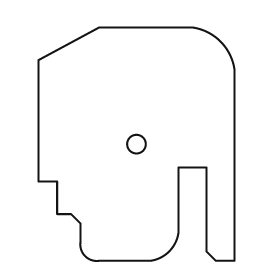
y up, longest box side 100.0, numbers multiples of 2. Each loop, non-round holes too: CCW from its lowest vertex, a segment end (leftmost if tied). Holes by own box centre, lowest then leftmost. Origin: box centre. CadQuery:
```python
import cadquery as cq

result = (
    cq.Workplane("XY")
    .moveTo(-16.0, -50.0)
    .lineTo(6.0, -50.0)
    .threePointArc((14.0, -46.0), (18.0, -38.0))
    .lineTo(18.0, -10.0)
    .lineTo(30.0, -10.0)
    .lineTo(30.0, -46.0)
    .lineTo(34.0, -50.0)
    .lineTo(42.0, -50.0)
    .lineTo(42.0, 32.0)
    .threePointArc((36.0, 44.0), (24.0, 50.0))
    .lineTo(-16.0, 50.0)
    .lineTo(-42.0, 36.0)
    .lineTo(-42.0, -16.0)
    .lineTo(-34.0, -16.0)
    .lineTo(-34.0, -30.0)
    .lineTo(-28.0, -30.0)
    .lineTo(-24.0, -34.0)
    .lineTo(-24.0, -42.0)
    .threePointArc((-22.0, -48.0), (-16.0, -50.0))
    .close()
    .moveTo(0.0, 0.0)
    .circle(4.0)
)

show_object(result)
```